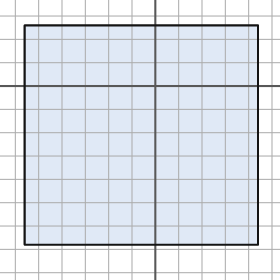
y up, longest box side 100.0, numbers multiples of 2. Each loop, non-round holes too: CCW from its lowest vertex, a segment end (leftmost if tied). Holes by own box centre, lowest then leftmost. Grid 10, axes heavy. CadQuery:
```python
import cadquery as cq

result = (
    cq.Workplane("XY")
    .moveTo(-56.0, -68.0)
    .lineTo(44.0, -68.0)
    .lineTo(44.0, 26.0)
    .lineTo(-56.0, 26.0)
    .close()
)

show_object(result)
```